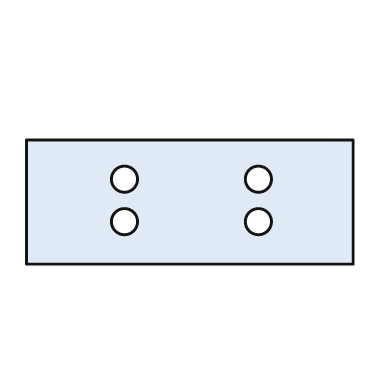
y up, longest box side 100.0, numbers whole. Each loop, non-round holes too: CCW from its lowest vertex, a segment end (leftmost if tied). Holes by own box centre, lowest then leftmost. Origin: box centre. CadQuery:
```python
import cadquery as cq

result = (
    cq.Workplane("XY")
    .moveTo(-50.0, -19.0)
    .lineTo(50.0, -19.0)
    .lineTo(50.0, 19.0)
    .lineTo(-50.0, 19.0)
    .close()
    .moveTo(-20.0, -6.0)
    .circle(4.0)
    .moveTo(21.0, -6.0)
    .circle(4.0)
    .moveTo(-20.0, 7.0)
    .circle(4.0)
    .moveTo(21.0, 7.0)
    .circle(4.0)
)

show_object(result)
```